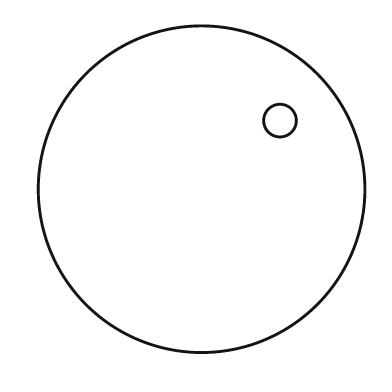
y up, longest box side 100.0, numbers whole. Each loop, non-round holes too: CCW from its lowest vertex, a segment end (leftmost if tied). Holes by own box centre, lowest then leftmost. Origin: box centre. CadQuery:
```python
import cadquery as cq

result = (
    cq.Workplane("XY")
    .moveTo(0.0, 0.0)
    .circle(50.0)
    .moveTo(24.0, 21.0)
    .circle(5.0)
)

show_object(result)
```